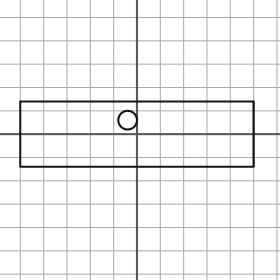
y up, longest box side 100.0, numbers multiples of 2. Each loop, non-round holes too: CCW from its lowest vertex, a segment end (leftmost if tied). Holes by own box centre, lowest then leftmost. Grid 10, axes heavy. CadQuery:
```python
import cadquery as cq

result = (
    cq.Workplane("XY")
    .moveTo(-50.0, -14.0)
    .lineTo(50.0, -14.0)
    .lineTo(50.0, 14.0)
    .lineTo(-50.0, 14.0)
    .close()
    .moveTo(-4.0, 6.0)
    .circle(4.0)
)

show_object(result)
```